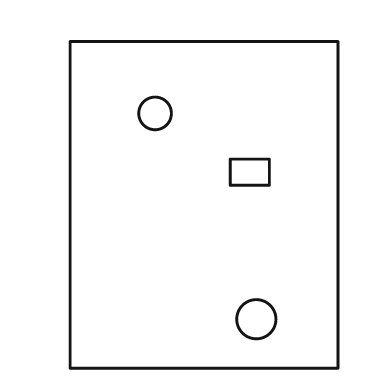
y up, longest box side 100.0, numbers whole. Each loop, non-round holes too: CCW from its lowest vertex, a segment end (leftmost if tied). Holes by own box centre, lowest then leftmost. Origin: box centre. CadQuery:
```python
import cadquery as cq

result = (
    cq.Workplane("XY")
    .moveTo(-41.0, -50.0)
    .lineTo(41.0, -50.0)
    .lineTo(41.0, 50.0)
    .lineTo(-41.0, 50.0)
    .close()
    .moveTo(16.0, -35.0)
    .circle(6.0)
    .moveTo(8.0, 6.0)
    .lineTo(20.0, 6.0)
    .lineTo(20.0, 14.0)
    .lineTo(8.0, 14.0)
    .close()
    .moveTo(-15.0, 28.0)
    .circle(5.0)
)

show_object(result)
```